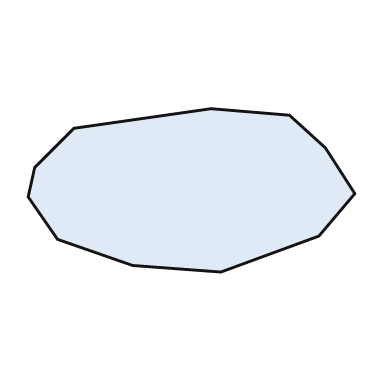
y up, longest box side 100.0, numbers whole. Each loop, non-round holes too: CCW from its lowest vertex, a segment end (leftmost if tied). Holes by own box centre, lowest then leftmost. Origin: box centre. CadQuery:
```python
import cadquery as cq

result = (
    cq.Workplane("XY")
    .moveTo(9.0, -25.0)
    .lineTo(39.0, -14.0)
    .lineTo(50.0, -1.0)
    .lineTo(41.0, 13.0)
    .lineTo(30.0, 23.0)
    .lineTo(6.0, 25.0)
    .lineTo(-36.0, 19.0)
    .lineTo(-48.0, 7.0)
    .lineTo(-50.0, -2.0)
    .lineTo(-41.0, -15.0)
    .lineTo(-18.0, -23.0)
    .close()
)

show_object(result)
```